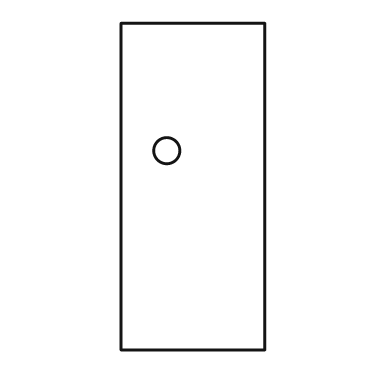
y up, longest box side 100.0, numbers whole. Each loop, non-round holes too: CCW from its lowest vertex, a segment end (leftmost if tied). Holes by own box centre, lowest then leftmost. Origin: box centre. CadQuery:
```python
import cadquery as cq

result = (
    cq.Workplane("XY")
    .moveTo(-22.0, -50.0)
    .lineTo(22.0, -50.0)
    .lineTo(22.0, 50.0)
    .lineTo(-22.0, 50.0)
    .close()
    .moveTo(-8.0, 11.0)
    .circle(4.0)
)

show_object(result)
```